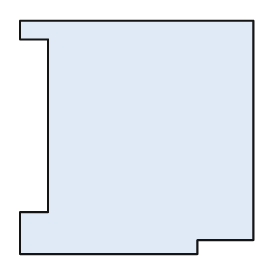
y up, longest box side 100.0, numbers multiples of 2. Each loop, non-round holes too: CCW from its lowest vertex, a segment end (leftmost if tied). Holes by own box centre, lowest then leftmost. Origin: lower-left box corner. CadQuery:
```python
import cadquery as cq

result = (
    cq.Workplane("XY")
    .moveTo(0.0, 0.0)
    .lineTo(76.0, 0.0)
    .lineTo(76.0, 6.0)
    .lineTo(100.0, 6.0)
    .lineTo(100.0, 100.0)
    .lineTo(0.0, 100.0)
    .lineTo(0.0, 92.0)
    .lineTo(12.0, 92.0)
    .lineTo(12.0, 18.0)
    .lineTo(0.0, 18.0)
    .close()
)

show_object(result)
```